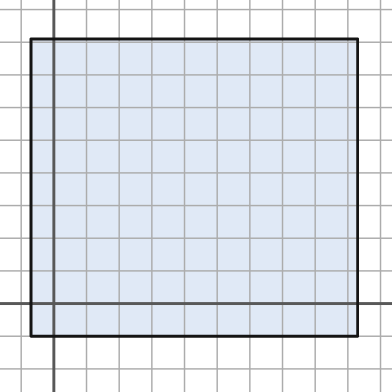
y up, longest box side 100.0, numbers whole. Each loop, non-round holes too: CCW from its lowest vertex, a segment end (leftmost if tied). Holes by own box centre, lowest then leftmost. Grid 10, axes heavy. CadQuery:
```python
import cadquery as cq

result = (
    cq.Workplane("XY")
    .moveTo(-7.0, -10.0)
    .lineTo(93.0, -10.0)
    .lineTo(93.0, 81.0)
    .lineTo(-7.0, 81.0)
    .close()
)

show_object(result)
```